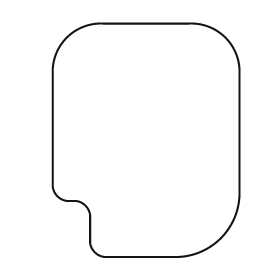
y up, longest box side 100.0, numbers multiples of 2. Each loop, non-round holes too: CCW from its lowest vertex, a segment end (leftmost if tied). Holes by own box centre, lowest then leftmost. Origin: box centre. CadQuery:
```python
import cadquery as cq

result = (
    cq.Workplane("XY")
    .moveTo(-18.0, -50.0)
    .lineTo(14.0, -50.0)
    .threePointArc((32.0, -42.0), (40.0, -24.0))
    .lineTo(40.0, 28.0)
    .threePointArc((34.0, 44.0), (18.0, 50.0))
    .lineTo(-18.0, 50.0)
    .threePointArc((-34.0, 44.0), (-40.0, 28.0))
    .lineTo(-40.0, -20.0)
    .threePointArc((-38.0, -24.0), (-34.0, -26.0))
    .lineTo(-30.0, -26.0)
    .threePointArc((-26.0, -28.0), (-24.0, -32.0))
    .lineTo(-24.0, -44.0)
    .threePointArc((-22.0, -48.0), (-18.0, -50.0))
    .close()
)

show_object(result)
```